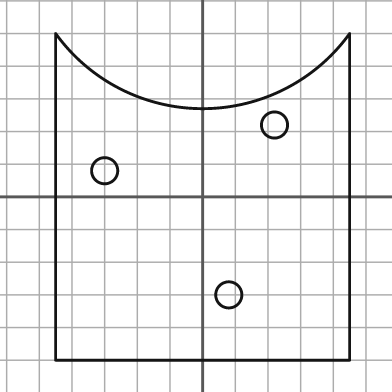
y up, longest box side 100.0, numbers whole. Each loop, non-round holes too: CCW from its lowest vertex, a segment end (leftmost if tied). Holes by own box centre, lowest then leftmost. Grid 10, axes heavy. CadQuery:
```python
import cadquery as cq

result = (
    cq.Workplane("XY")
    .moveTo(-45.0, -50.0)
    .lineTo(45.0, -50.0)
    .lineTo(45.0, 50.0)
    .threePointArc((0.0, 27.0), (-45.0, 50.0))
    .close()
    .moveTo(8.0, -30.0)
    .circle(4.0)
    .moveTo(-30.0, 8.0)
    .circle(4.0)
    .moveTo(22.0, 22.0)
    .circle(4.0)
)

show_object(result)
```